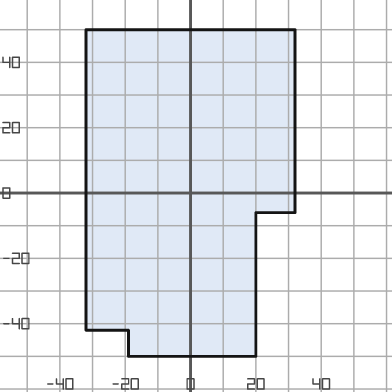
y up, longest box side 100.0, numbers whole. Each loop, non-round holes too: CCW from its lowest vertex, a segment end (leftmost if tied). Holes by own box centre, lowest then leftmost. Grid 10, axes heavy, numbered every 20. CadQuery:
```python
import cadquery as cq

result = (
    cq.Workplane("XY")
    .moveTo(-19.0, -50.0)
    .lineTo(20.0, -50.0)
    .lineTo(20.0, -6.0)
    .lineTo(32.0, -6.0)
    .lineTo(32.0, 50.0)
    .lineTo(-32.0, 50.0)
    .lineTo(-32.0, -42.0)
    .lineTo(-19.0, -42.0)
    .close()
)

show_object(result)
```